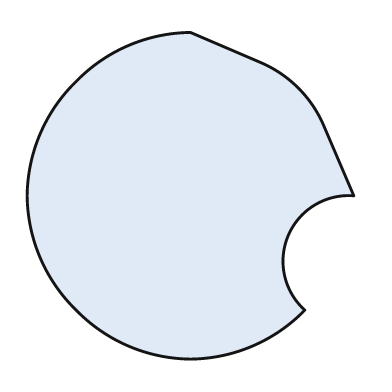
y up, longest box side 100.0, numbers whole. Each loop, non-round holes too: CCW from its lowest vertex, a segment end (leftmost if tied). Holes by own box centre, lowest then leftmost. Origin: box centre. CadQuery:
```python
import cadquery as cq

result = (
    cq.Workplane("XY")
    .moveTo(0.0, -50.0)
    .threePointArc((19.0, -46.0), (35.0, -35.0))
    .threePointArc((30.0, -12.0), (50.0, 0.0))
    .lineTo(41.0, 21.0)
    .threePointArc((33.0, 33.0), (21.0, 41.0))
    .lineTo(0.0, 50.0)
    .threePointArc((-19.0, 46.0), (-35.0, 35.0))
    .threePointArc((-46.0, 19.0), (-50.0, 0.0))
    .threePointArc((-46.0, -19.0), (-35.0, -35.0))
    .threePointArc((-19.0, -46.0), (0.0, -50.0))
    .close()
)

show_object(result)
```